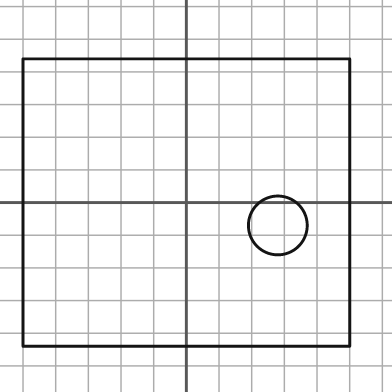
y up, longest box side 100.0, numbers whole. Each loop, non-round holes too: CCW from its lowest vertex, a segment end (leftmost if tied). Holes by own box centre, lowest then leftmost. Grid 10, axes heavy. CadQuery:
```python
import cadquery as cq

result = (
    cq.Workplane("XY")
    .moveTo(-50.0, -44.0)
    .lineTo(50.0, -44.0)
    .lineTo(50.0, 44.0)
    .lineTo(-50.0, 44.0)
    .close()
    .moveTo(28.0, -7.0)
    .circle(9.0)
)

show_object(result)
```